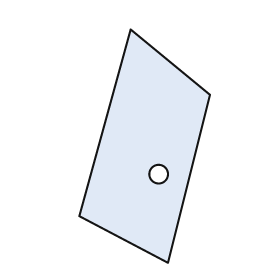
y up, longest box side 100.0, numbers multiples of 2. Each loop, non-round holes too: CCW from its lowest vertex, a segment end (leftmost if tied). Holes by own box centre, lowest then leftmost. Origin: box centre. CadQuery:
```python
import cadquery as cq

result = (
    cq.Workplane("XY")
    .moveTo(10.0, -50.0)
    .lineTo(28.0, 22.0)
    .lineTo(-6.0, 50.0)
    .lineTo(-28.0, -30.0)
    .close()
    .moveTo(6.0, -12.0)
    .circle(4.0)
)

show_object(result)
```